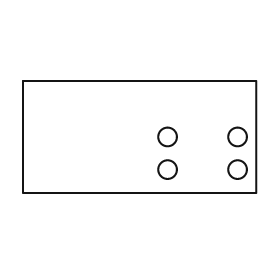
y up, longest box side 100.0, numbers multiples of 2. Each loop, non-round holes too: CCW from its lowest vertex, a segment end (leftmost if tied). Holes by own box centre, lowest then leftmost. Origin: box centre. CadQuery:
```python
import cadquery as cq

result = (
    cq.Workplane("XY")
    .moveTo(-50.0, -24.0)
    .lineTo(50.0, -24.0)
    .lineTo(50.0, 24.0)
    .lineTo(-50.0, 24.0)
    .close()
    .moveTo(12.0, -14.0)
    .circle(4.0)
    .moveTo(42.0, -14.0)
    .circle(4.0)
    .moveTo(12.0, 0.0)
    .circle(4.0)
    .moveTo(42.0, 0.0)
    .circle(4.0)
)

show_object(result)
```